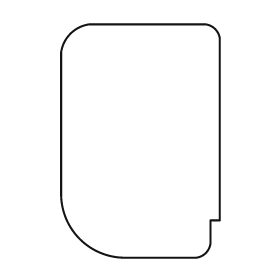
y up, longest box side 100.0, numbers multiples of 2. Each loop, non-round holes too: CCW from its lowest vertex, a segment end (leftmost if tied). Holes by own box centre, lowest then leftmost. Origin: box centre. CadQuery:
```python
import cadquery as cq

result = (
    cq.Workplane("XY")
    .moveTo(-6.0, -50.0)
    .lineTo(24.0, -50.0)
    .threePointArc((28.0, -48.0), (30.0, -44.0))
    .lineTo(30.0, -34.0)
    .lineTo(34.0, -34.0)
    .lineTo(34.0, 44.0)
    .threePointArc((32.0, 48.0), (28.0, 50.0))
    .lineTo(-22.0, 50.0)
    .threePointArc((-30.0, 46.0), (-34.0, 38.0))
    .lineTo(-34.0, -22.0)
    .threePointArc((-26.0, -42.0), (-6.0, -50.0))
    .close()
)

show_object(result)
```